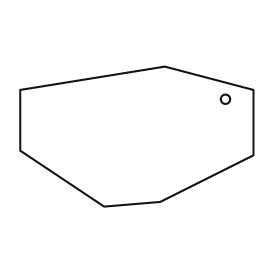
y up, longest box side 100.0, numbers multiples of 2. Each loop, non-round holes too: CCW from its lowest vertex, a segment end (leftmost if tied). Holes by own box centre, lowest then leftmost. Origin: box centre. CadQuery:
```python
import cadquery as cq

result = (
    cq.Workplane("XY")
    .moveTo(-14.0, -30.0)
    .lineTo(10.0, -28.0)
    .lineTo(50.0, -8.0)
    .lineTo(50.0, 20.0)
    .lineTo(12.0, 30.0)
    .lineTo(-50.0, 20.0)
    .lineTo(-50.0, -6.0)
    .close()
    .moveTo(38.0, 16.0)
    .circle(2.0)
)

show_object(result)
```